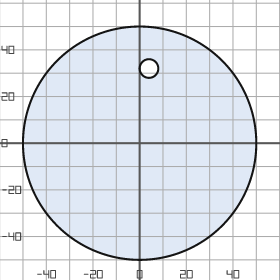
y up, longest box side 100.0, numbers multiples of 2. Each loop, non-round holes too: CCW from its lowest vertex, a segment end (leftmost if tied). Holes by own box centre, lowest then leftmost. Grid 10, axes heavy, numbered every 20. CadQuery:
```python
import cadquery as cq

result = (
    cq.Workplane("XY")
    .moveTo(0.0, 0.0)
    .circle(50.0)
    .moveTo(4.0, 32.0)
    .circle(4.0)
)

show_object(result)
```